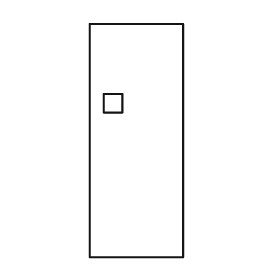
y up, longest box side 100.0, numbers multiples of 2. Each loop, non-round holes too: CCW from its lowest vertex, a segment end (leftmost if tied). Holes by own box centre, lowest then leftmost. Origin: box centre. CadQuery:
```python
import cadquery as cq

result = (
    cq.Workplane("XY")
    .moveTo(-20.0, -50.0)
    .lineTo(20.0, -50.0)
    .lineTo(20.0, 50.0)
    .lineTo(-20.0, 50.0)
    .close()
    .moveTo(-14.0, 12.0)
    .lineTo(-6.0, 12.0)
    .lineTo(-6.0, 20.0)
    .lineTo(-14.0, 20.0)
    .close()
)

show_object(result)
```